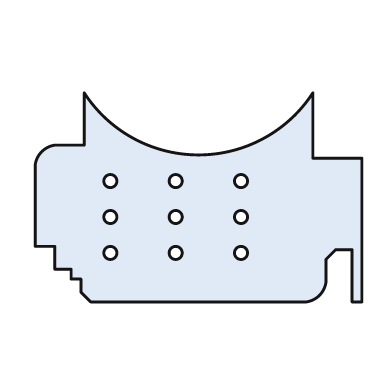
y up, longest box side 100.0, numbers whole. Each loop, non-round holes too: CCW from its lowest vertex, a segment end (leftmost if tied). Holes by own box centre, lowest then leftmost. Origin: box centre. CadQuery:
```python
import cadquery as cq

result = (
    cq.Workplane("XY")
    .moveTo(-33.0, -32.0)
    .lineTo(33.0, -32.0)
    .threePointArc((37.0, -30.0), (39.0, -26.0))
    .lineTo(39.0, -19.0)
    .lineTo(42.0, -16.0)
    .lineTo(47.0, -16.0)
    .lineTo(47.0, -32.0)
    .lineTo(50.0, -32.0)
    .lineTo(50.0, 12.0)
    .lineTo(35.0, 12.0)
    .lineTo(35.0, 32.0)
    .threePointArc((0.0, 13.0), (-35.0, 32.0))
    .lineTo(-35.0, 16.0)
    .lineTo(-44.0, 16.0)
    .threePointArc((-48.0, 14.0), (-50.0, 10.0))
    .lineTo(-50.0, -15.0)
    .lineTo(-44.0, -15.0)
    .lineTo(-44.0, -22.0)
    .lineTo(-39.0, -22.0)
    .lineTo(-39.0, -25.0)
    .lineTo(-36.0, -25.0)
    .lineTo(-36.0, -29.0)
    .close()
    .moveTo(-27.0, -17.0)
    .circle(2.0)
    .moveTo(-7.0, -17.0)
    .circle(2.0)
    .moveTo(13.0, -17.0)
    .circle(2.0)
    .moveTo(-27.0, -6.0)
    .circle(2.0)
    .moveTo(-7.0, -6.0)
    .circle(2.0)
    .moveTo(13.0, -6.0)
    .circle(2.0)
    .moveTo(-27.0, 5.0)
    .circle(2.0)
    .moveTo(-7.0, 5.0)
    .circle(2.0)
    .moveTo(13.0, 5.0)
    .circle(2.0)
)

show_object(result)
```